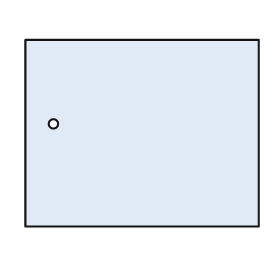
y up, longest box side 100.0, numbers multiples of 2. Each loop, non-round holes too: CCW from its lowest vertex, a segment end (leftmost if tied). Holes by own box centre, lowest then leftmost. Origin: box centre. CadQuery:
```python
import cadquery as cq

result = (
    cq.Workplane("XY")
    .moveTo(-50.0, -40.0)
    .lineTo(50.0, -40.0)
    .lineTo(50.0, 40.0)
    .lineTo(-50.0, 40.0)
    .close()
    .moveTo(-38.0, 4.0)
    .circle(2.0)
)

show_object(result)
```